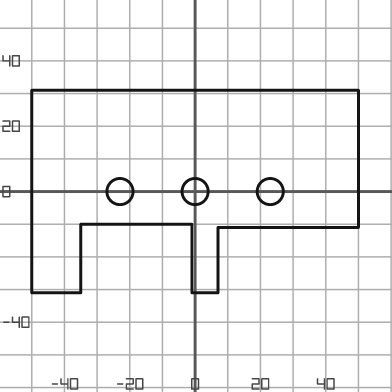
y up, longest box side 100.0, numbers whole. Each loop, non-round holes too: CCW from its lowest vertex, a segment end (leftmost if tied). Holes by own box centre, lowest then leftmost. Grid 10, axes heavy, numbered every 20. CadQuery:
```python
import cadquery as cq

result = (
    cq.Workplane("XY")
    .moveTo(-50.0, -31.0)
    .lineTo(-35.0, -31.0)
    .lineTo(-35.0, -10.0)
    .lineTo(-1.0, -10.0)
    .lineTo(-1.0, -31.0)
    .lineTo(7.0, -31.0)
    .lineTo(7.0, -11.0)
    .lineTo(50.0, -11.0)
    .lineTo(50.0, 31.0)
    .lineTo(-50.0, 31.0)
    .close()
    .moveTo(-23.0, 0.0)
    .circle(4.0)
    .moveTo(0.0, 0.0)
    .circle(4.0)
    .moveTo(23.0, 0.0)
    .circle(4.0)
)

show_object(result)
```